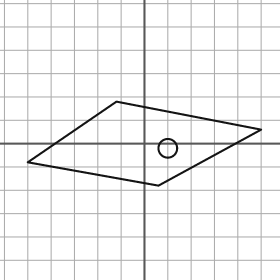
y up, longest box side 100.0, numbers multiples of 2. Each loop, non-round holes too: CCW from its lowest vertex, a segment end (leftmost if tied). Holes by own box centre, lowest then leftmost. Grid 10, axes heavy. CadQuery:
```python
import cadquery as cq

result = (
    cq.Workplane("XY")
    .moveTo(6.0, -18.0)
    .lineTo(50.0, 6.0)
    .lineTo(-12.0, 18.0)
    .lineTo(-50.0, -8.0)
    .close()
    .moveTo(10.0, -2.0)
    .circle(4.0)
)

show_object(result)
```